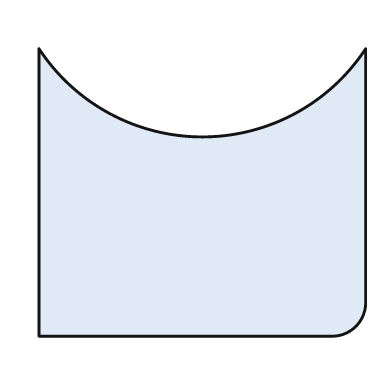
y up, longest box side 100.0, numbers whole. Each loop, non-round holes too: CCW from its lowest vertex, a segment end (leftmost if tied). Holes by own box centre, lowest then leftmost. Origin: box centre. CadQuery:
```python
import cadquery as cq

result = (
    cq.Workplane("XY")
    .moveTo(-50.0, -44.0)
    .lineTo(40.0, -44.0)
    .threePointArc((47.0, -41.0), (50.0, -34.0))
    .lineTo(50.0, 44.0)
    .threePointArc((0.0, 17.0), (-50.0, 44.0))
    .close()
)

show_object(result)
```